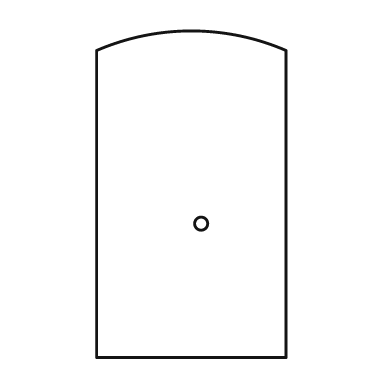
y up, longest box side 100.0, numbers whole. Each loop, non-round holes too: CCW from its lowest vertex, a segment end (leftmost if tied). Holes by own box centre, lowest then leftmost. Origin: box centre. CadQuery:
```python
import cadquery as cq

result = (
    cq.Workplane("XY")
    .moveTo(-29.0, -50.0)
    .lineTo(29.0, -50.0)
    .lineTo(29.0, 44.0)
    .threePointArc((0.0, 50.0), (-29.0, 44.0))
    .close()
    .moveTo(3.0, -9.0)
    .circle(2.0)
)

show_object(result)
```